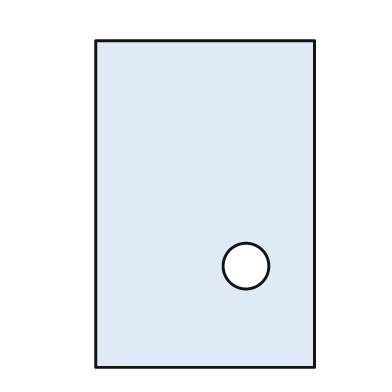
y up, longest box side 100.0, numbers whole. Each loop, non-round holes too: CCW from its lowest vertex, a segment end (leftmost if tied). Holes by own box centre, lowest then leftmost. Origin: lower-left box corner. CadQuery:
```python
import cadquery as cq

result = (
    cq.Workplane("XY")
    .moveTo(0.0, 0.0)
    .lineTo(67.0, 0.0)
    .lineTo(67.0, 100.0)
    .lineTo(0.0, 100.0)
    .close()
    .moveTo(46.0, 31.0)
    .circle(7.0)
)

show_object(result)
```